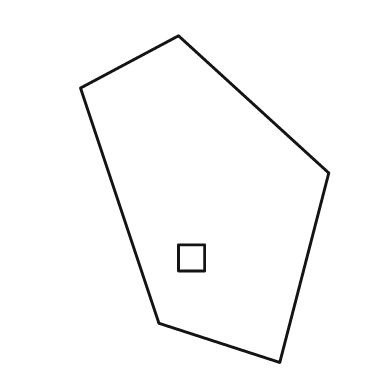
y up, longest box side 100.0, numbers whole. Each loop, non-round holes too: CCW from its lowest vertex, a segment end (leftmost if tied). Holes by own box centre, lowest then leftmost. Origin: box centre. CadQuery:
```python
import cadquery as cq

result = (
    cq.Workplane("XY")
    .moveTo(23.0, -50.0)
    .lineTo(38.0, 8.0)
    .lineTo(-8.0, 50.0)
    .lineTo(-38.0, 34.0)
    .lineTo(-14.0, -38.0)
    .close()
    .moveTo(-8.0, -22.0)
    .lineTo(0.0, -22.0)
    .lineTo(0.0, -14.0)
    .lineTo(-8.0, -14.0)
    .close()
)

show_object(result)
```